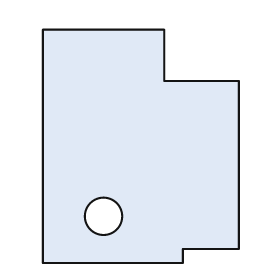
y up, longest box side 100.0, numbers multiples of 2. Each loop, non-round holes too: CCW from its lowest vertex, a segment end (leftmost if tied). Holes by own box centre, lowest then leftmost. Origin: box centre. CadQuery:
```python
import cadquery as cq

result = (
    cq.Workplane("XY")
    .moveTo(-42.0, -50.0)
    .lineTo(18.0, -50.0)
    .lineTo(18.0, -44.0)
    .lineTo(42.0, -44.0)
    .lineTo(42.0, 28.0)
    .lineTo(10.0, 28.0)
    .lineTo(10.0, 50.0)
    .lineTo(-42.0, 50.0)
    .close()
    .moveTo(-16.0, -30.0)
    .circle(8.0)
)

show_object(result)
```